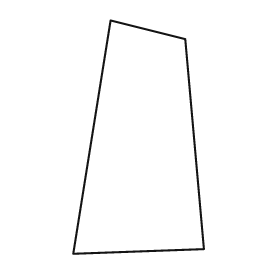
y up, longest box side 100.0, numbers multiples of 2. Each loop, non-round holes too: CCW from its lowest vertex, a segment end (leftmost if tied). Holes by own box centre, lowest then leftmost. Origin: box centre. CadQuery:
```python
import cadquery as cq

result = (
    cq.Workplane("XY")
    .moveTo(-28.0, -50.0)
    .lineTo(28.0, -48.0)
    .lineTo(20.0, 42.0)
    .lineTo(-12.0, 50.0)
    .close()
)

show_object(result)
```